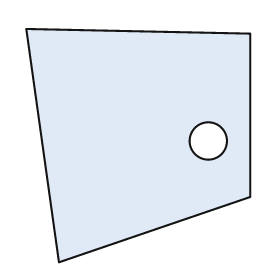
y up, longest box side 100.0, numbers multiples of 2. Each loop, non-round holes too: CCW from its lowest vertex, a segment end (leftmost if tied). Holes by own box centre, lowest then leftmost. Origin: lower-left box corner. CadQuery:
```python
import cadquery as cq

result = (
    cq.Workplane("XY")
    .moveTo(14.0, 0.0)
    .lineTo(96.0, 28.0)
    .lineTo(96.0, 98.0)
    .lineTo(0.0, 100.0)
    .close()
    .moveTo(78.0, 52.0)
    .circle(8.0)
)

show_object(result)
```